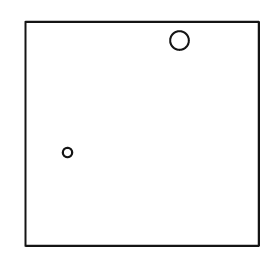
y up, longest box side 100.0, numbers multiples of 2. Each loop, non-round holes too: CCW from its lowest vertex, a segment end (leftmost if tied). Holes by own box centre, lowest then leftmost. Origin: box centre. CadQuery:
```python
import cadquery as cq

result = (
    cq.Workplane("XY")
    .moveTo(-50.0, -48.0)
    .lineTo(50.0, -48.0)
    .lineTo(50.0, 48.0)
    .lineTo(-50.0, 48.0)
    .close()
    .moveTo(-32.0, -8.0)
    .circle(2.0)
    .moveTo(16.0, 40.0)
    .circle(4.0)
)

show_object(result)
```